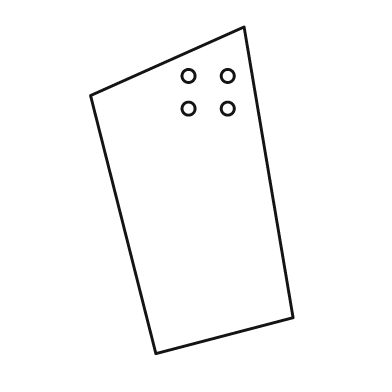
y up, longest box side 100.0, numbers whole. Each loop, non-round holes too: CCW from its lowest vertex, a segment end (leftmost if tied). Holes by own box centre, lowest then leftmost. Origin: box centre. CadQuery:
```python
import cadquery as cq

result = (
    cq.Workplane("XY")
    .moveTo(-11.0, -50.0)
    .lineTo(31.0, -39.0)
    .lineTo(16.0, 50.0)
    .lineTo(-31.0, 29.0)
    .close()
    .moveTo(-1.0, 25.0)
    .circle(2.0)
    .moveTo(11.0, 25.0)
    .circle(2.0)
    .moveTo(-1.0, 35.0)
    .circle(2.0)
    .moveTo(11.0, 35.0)
    .circle(2.0)
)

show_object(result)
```